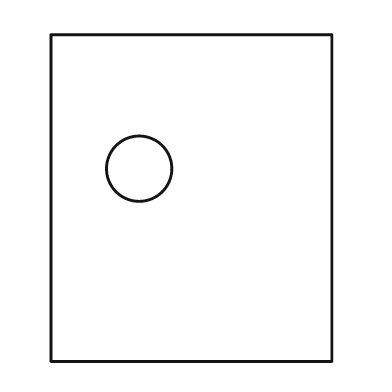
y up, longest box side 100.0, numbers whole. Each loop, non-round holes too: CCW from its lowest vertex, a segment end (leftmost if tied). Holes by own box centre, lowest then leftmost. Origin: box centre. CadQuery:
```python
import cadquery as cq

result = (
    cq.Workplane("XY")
    .moveTo(-43.0, -50.0)
    .lineTo(43.0, -50.0)
    .lineTo(43.0, 50.0)
    .lineTo(-43.0, 50.0)
    .close()
    .moveTo(-16.0, 9.0)
    .circle(10.0)
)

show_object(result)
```